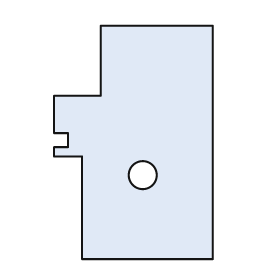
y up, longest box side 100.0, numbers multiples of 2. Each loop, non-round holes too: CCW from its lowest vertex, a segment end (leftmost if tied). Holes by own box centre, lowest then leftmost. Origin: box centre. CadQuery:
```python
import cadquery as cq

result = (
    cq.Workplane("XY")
    .moveTo(-22.0, -50.0)
    .lineTo(34.0, -50.0)
    .lineTo(34.0, 50.0)
    .lineTo(-14.0, 50.0)
    .lineTo(-14.0, 20.0)
    .lineTo(-34.0, 20.0)
    .lineTo(-34.0, 4.0)
    .lineTo(-28.0, 4.0)
    .lineTo(-28.0, -2.0)
    .lineTo(-34.0, -2.0)
    .lineTo(-34.0, -6.0)
    .lineTo(-22.0, -6.0)
    .close()
    .moveTo(4.0, -14.0)
    .circle(6.0)
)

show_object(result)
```